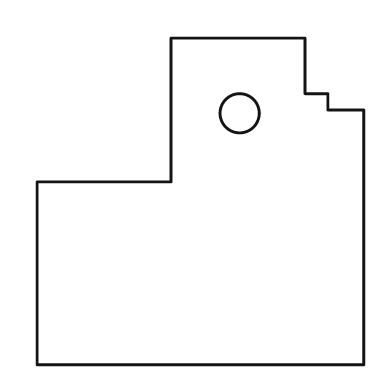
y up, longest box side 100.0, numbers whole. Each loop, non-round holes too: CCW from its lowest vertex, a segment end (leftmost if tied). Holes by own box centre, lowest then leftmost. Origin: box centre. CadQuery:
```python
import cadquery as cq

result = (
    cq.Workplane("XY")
    .moveTo(-50.0, -50.0)
    .lineTo(50.0, -50.0)
    .lineTo(50.0, 28.0)
    .lineTo(39.0, 28.0)
    .lineTo(39.0, 33.0)
    .lineTo(32.0, 33.0)
    .lineTo(32.0, 50.0)
    .lineTo(-9.0, 50.0)
    .lineTo(-9.0, 6.0)
    .lineTo(-50.0, 6.0)
    .close()
    .moveTo(12.0, 27.0)
    .circle(6.0)
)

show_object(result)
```